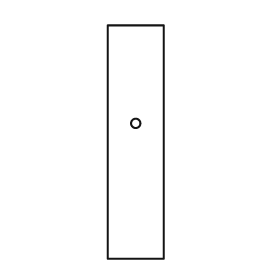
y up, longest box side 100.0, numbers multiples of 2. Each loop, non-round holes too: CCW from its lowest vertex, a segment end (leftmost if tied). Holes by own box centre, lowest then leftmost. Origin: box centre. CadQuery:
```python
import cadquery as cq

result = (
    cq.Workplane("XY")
    .moveTo(-12.0, -50.0)
    .lineTo(12.0, -50.0)
    .lineTo(12.0, 50.0)
    .lineTo(-12.0, 50.0)
    .close()
    .moveTo(0.0, 8.0)
    .circle(2.0)
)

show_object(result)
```